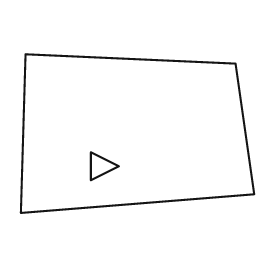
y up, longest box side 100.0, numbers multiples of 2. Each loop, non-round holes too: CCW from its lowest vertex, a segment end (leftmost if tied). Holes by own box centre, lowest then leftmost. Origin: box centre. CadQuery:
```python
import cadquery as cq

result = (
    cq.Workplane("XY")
    .moveTo(-50.0, -34.0)
    .lineTo(50.0, -26.0)
    .lineTo(42.0, 30.0)
    .lineTo(-48.0, 34.0)
    .close()
    .moveTo(-20.0, -20.0)
    .lineTo(-8.0, -14.0)
    .lineTo(-20.0, -8.0)
    .close()
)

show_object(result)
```